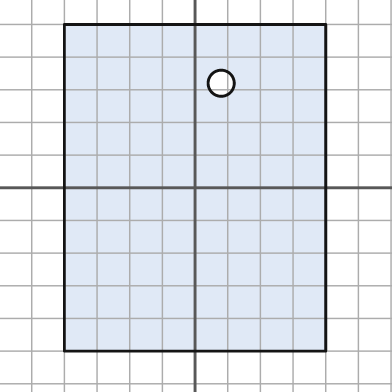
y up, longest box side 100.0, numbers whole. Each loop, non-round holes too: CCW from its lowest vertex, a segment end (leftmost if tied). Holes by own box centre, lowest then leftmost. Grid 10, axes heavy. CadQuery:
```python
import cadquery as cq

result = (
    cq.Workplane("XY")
    .moveTo(-40.0, -50.0)
    .lineTo(40.0, -50.0)
    .lineTo(40.0, 50.0)
    .lineTo(-40.0, 50.0)
    .close()
    .moveTo(8.0, 32.0)
    .circle(4.0)
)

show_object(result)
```